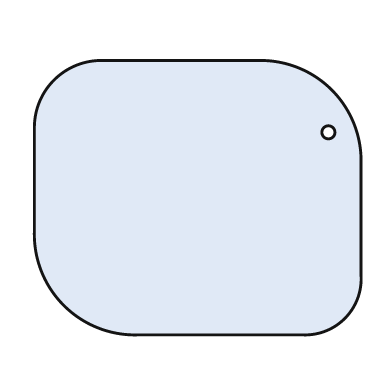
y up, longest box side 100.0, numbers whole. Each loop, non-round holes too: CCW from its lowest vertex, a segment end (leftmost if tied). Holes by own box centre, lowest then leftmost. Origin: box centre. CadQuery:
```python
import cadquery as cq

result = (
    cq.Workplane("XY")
    .moveTo(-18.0, -42.0)
    .lineTo(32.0, -42.0)
    .threePointArc((45.0, -37.0), (50.0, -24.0))
    .lineTo(50.0, 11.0)
    .threePointArc((41.0, 33.0), (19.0, 42.0))
    .lineTo(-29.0, 42.0)
    .threePointArc((-44.0, 36.0), (-50.0, 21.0))
    .lineTo(-50.0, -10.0)
    .threePointArc((-41.0, -33.0), (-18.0, -42.0))
    .close()
    .moveTo(40.0, 20.0)
    .circle(2.0)
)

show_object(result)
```